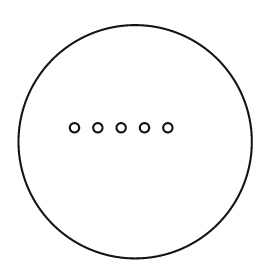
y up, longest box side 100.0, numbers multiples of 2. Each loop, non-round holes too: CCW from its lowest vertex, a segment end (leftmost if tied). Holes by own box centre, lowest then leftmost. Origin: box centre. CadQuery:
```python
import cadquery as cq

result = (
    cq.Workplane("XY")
    .moveTo(0.0, 0.0)
    .circle(50.0)
    .moveTo(-26.0, 6.0)
    .circle(2.0)
    .moveTo(-16.0, 6.0)
    .circle(2.0)
    .moveTo(-6.0, 6.0)
    .circle(2.0)
    .moveTo(4.0, 6.0)
    .circle(2.0)
    .moveTo(14.0, 6.0)
    .circle(2.0)
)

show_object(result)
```